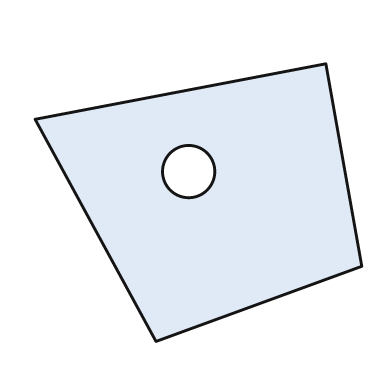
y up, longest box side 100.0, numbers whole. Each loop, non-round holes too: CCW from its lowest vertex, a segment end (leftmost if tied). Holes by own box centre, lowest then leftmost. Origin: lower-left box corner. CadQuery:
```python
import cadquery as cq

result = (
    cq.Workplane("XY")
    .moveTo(37.0, 0.0)
    .lineTo(100.0, 23.0)
    .lineTo(89.0, 85.0)
    .lineTo(0.0, 68.0)
    .close()
    .moveTo(47.0, 52.0)
    .circle(8.0)
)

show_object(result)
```